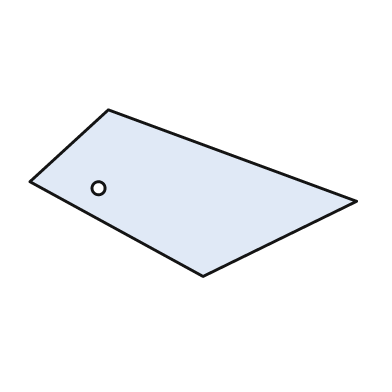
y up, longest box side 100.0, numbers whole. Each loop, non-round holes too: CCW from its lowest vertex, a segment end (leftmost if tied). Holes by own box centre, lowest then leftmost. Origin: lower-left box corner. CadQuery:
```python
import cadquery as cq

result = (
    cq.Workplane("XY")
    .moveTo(53.0, 0.0)
    .lineTo(100.0, 23.0)
    .lineTo(24.0, 51.0)
    .lineTo(0.0, 29.0)
    .close()
    .moveTo(21.0, 27.0)
    .circle(2.0)
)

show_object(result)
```